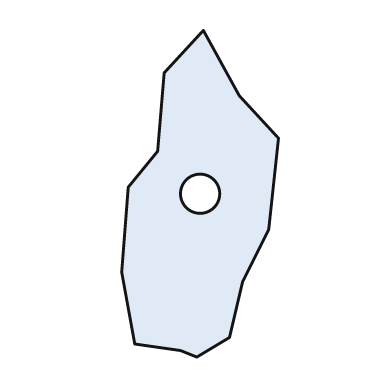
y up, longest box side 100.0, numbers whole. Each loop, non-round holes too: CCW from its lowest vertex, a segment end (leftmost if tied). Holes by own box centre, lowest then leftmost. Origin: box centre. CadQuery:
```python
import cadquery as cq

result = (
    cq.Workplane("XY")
    .moveTo(-1.0, -50.0)
    .lineTo(9.0, -44.0)
    .lineTo(13.0, -27.0)
    .lineTo(21.0, -11.0)
    .lineTo(24.0, 17.0)
    .lineTo(12.0, 30.0)
    .lineTo(1.0, 50.0)
    .lineTo(-11.0, 37.0)
    .lineTo(-13.0, 13.0)
    .lineTo(-22.0, 2.0)
    .lineTo(-24.0, -24.0)
    .lineTo(-20.0, -46.0)
    .lineTo(-6.0, -48.0)
    .close()
    .moveTo(0.0, 0.0)
    .circle(6.0)
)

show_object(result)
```